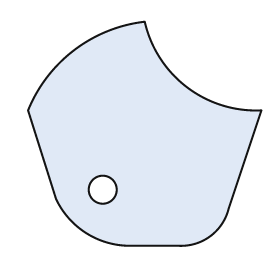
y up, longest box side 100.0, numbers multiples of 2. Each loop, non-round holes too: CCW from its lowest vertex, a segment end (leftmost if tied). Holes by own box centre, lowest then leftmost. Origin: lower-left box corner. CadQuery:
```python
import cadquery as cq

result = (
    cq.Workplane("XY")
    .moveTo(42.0, 0.0)
    .lineTo(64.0, 0.0)
    .threePointArc((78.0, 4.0), (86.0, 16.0))
    .lineTo(100.0, 58.0)
    .threePointArc((68.0, 68.0), (50.0, 96.0))
    .threePointArc((20.0, 84.0), (0.0, 58.0))
    .lineTo(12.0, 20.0)
    .threePointArc((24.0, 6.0), (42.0, 0.0))
    .close()
    .moveTo(32.0, 24.0)
    .circle(6.0)
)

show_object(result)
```